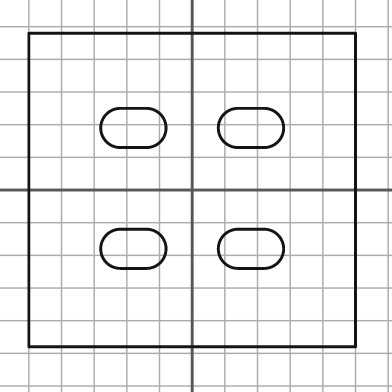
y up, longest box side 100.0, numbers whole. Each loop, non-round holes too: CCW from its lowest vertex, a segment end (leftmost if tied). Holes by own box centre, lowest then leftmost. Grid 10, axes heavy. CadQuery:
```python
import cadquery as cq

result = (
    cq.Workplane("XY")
    .moveTo(-50.0, -48.0)
    .lineTo(50.0, -48.0)
    .lineTo(50.0, 48.0)
    .lineTo(-50.0, 48.0)
    .close()
    .moveTo(-22.0, -24.0)
    .lineTo(-14.0, -24.0)
    .threePointArc((-8.0, -18.0), (-14.0, -12.0))
    .lineTo(-22.0, -12.0)
    .threePointArc((-28.0, -18.0), (-22.0, -24.0))
    .close()
    .moveTo(14.0, -24.0)
    .lineTo(22.0, -24.0)
    .threePointArc((28.0, -18.0), (22.0, -12.0))
    .lineTo(14.0, -12.0)
    .threePointArc((8.0, -18.0), (14.0, -24.0))
    .close()
    .moveTo(-22.0, 13.0)
    .lineTo(-14.0, 13.0)
    .threePointArc((-8.0, 19.0), (-14.0, 25.0))
    .lineTo(-22.0, 25.0)
    .threePointArc((-28.0, 19.0), (-22.0, 13.0))
    .close()
    .moveTo(14.0, 13.0)
    .lineTo(22.0, 13.0)
    .threePointArc((28.0, 19.0), (22.0, 25.0))
    .lineTo(14.0, 25.0)
    .threePointArc((8.0, 19.0), (14.0, 13.0))
    .close()
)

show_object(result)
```